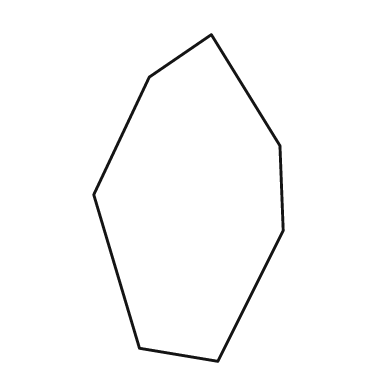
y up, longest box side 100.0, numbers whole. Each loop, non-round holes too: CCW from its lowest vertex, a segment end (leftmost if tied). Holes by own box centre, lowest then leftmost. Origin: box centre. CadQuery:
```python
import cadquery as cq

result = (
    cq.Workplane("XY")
    .moveTo(9.0, -50.0)
    .lineTo(29.0, -10.0)
    .lineTo(28.0, 16.0)
    .lineTo(7.0, 50.0)
    .lineTo(-12.0, 37.0)
    .lineTo(-29.0, 1.0)
    .lineTo(-15.0, -46.0)
    .close()
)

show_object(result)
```